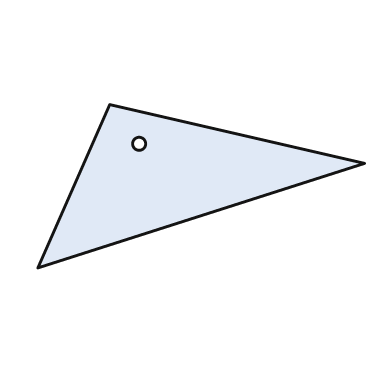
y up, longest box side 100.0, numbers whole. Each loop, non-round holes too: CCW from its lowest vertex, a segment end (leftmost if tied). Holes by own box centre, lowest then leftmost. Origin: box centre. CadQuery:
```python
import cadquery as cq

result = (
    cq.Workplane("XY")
    .moveTo(-50.0, -25.0)
    .lineTo(50.0, 7.0)
    .lineTo(-28.0, 25.0)
    .close()
    .moveTo(-19.0, 13.0)
    .circle(2.0)
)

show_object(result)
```